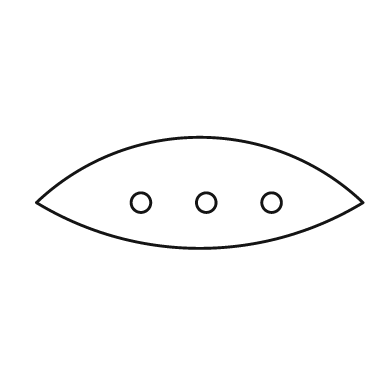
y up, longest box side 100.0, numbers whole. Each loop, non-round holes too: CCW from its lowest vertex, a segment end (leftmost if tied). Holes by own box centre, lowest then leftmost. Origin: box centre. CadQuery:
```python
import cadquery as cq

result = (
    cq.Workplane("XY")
    .moveTo(-50.0, -3.0)
    .threePointArc((0.0, -17.0), (50.0, -3.0))
    .threePointArc((0.0, 17.0), (-50.0, -3.0))
    .close()
    .moveTo(-18.0, -3.0)
    .circle(3.0)
    .moveTo(2.0, -3.0)
    .circle(3.0)
    .moveTo(22.0, -3.0)
    .circle(3.0)
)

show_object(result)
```